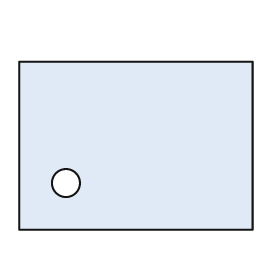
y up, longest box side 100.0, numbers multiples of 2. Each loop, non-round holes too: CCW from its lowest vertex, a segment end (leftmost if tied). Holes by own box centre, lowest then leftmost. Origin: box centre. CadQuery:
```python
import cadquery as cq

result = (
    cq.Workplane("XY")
    .moveTo(-50.0, -36.0)
    .lineTo(50.0, -36.0)
    .lineTo(50.0, 36.0)
    .lineTo(-50.0, 36.0)
    .close()
    .moveTo(-30.0, -16.0)
    .circle(6.0)
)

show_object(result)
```